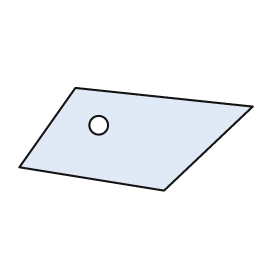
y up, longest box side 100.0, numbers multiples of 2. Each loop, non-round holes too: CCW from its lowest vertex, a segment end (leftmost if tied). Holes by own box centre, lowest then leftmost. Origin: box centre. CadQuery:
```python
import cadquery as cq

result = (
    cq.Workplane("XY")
    .moveTo(12.0, -22.0)
    .lineTo(50.0, 14.0)
    .lineTo(-26.0, 22.0)
    .lineTo(-50.0, -12.0)
    .close()
    .moveTo(-16.0, 6.0)
    .circle(4.0)
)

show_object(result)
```